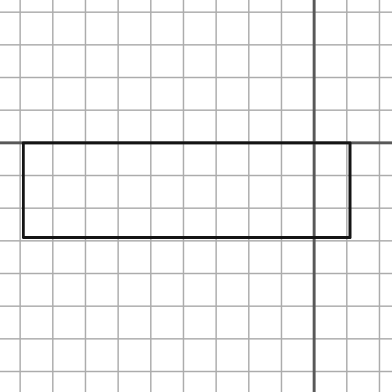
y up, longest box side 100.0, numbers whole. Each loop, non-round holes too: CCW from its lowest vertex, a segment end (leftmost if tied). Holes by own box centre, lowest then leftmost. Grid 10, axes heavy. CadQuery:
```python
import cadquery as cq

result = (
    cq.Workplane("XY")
    .moveTo(-89.0, -29.0)
    .lineTo(11.0, -29.0)
    .lineTo(11.0, 0.0)
    .lineTo(-89.0, 0.0)
    .close()
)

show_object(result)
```